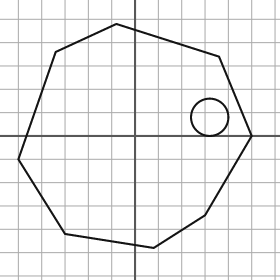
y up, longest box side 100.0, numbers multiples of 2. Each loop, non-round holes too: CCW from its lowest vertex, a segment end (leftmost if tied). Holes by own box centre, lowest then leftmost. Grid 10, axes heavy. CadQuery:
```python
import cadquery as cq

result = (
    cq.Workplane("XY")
    .moveTo(8.0, -48.0)
    .lineTo(30.0, -34.0)
    .lineTo(50.0, 0.0)
    .lineTo(36.0, 34.0)
    .lineTo(-8.0, 48.0)
    .lineTo(-34.0, 36.0)
    .lineTo(-50.0, -10.0)
    .lineTo(-30.0, -42.0)
    .close()
    .moveTo(32.0, 8.0)
    .circle(8.0)
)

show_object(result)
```